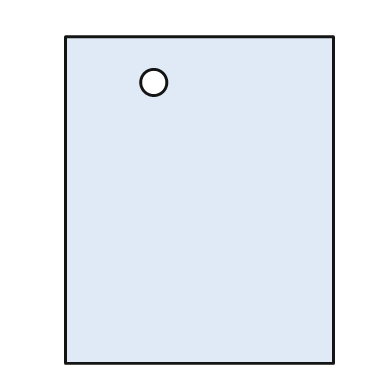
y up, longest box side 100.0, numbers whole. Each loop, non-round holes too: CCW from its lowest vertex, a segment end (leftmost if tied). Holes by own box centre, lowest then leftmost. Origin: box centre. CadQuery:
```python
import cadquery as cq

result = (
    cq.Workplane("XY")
    .moveTo(-41.0, -50.0)
    .lineTo(41.0, -50.0)
    .lineTo(41.0, 50.0)
    .lineTo(-41.0, 50.0)
    .close()
    .moveTo(-14.0, 36.0)
    .circle(4.0)
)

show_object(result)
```